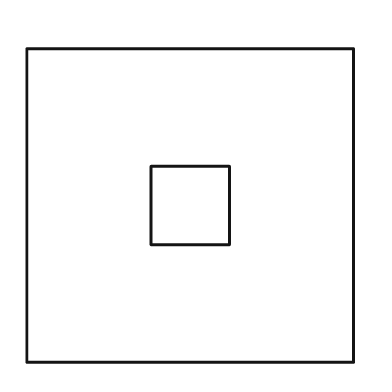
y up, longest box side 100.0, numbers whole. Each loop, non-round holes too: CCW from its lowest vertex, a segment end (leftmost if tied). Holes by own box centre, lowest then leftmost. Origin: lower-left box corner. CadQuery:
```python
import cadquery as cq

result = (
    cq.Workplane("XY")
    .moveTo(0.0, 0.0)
    .lineTo(100.0, 0.0)
    .lineTo(100.0, 96.0)
    .lineTo(0.0, 96.0)
    .close()
    .moveTo(38.0, 36.0)
    .lineTo(62.0, 36.0)
    .lineTo(62.0, 60.0)
    .lineTo(38.0, 60.0)
    .close()
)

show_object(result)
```